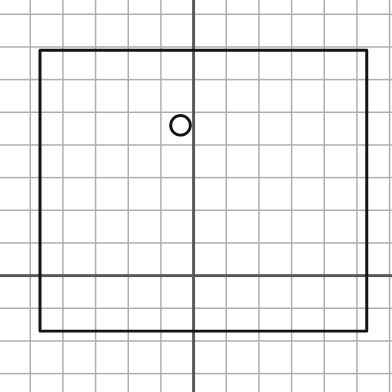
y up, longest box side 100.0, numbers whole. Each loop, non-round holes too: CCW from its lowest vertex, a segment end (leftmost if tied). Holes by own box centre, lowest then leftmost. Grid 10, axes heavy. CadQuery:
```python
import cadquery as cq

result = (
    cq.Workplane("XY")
    .moveTo(-47.0, -17.0)
    .lineTo(53.0, -17.0)
    .lineTo(53.0, 69.0)
    .lineTo(-47.0, 69.0)
    .close()
    .moveTo(-4.0, 46.0)
    .circle(3.0)
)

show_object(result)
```